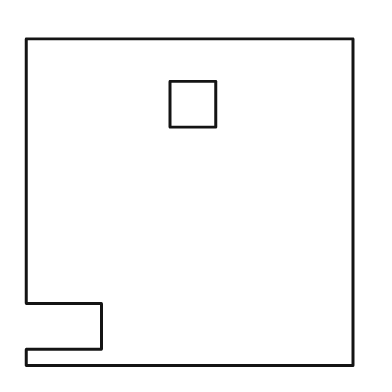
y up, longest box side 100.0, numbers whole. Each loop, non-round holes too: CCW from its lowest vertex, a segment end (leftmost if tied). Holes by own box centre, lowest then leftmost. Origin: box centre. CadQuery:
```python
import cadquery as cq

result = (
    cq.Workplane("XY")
    .moveTo(-50.0, -50.0)
    .lineTo(50.0, -50.0)
    .lineTo(50.0, 50.0)
    .lineTo(-50.0, 50.0)
    .lineTo(-50.0, -31.0)
    .lineTo(-27.0, -31.0)
    .lineTo(-27.0, -45.0)
    .lineTo(-50.0, -45.0)
    .close()
    .moveTo(-6.0, 23.0)
    .lineTo(8.0, 23.0)
    .lineTo(8.0, 37.0)
    .lineTo(-6.0, 37.0)
    .close()
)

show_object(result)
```